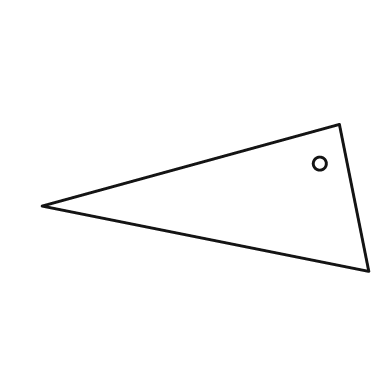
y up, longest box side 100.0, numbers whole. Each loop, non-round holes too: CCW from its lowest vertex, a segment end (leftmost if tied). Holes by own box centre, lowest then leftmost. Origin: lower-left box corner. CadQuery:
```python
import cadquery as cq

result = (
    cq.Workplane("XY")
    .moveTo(100.0, 0.0)
    .lineTo(91.0, 45.0)
    .lineTo(0.0, 20.0)
    .close()
    .moveTo(85.0, 33.0)
    .circle(2.0)
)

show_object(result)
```